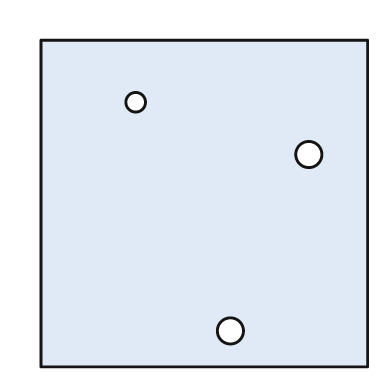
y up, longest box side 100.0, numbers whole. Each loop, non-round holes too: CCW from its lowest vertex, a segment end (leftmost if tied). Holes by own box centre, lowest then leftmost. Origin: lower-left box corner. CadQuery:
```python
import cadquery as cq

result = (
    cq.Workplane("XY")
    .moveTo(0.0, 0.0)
    .lineTo(100.0, 0.0)
    .lineTo(100.0, 100.0)
    .lineTo(0.0, 100.0)
    .close()
    .moveTo(58.0, 11.0)
    .circle(4.0)
    .moveTo(82.0, 65.0)
    .circle(4.0)
    .moveTo(29.0, 81.0)
    .circle(3.0)
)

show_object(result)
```